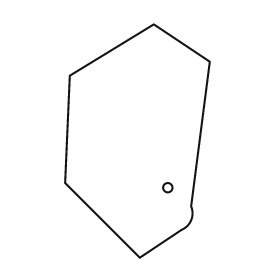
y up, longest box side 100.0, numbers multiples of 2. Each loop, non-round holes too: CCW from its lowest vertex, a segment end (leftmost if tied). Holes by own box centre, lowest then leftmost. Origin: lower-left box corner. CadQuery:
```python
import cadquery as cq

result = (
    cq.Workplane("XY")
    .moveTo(32.0, 0.0)
    .lineTo(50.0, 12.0)
    .threePointArc((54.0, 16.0), (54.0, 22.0))
    .lineTo(62.0, 84.0)
    .lineTo(38.0, 100.0)
    .lineTo(2.0, 78.0)
    .lineTo(0.0, 32.0)
    .close()
    .moveTo(44.0, 30.0)
    .circle(2.0)
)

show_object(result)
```